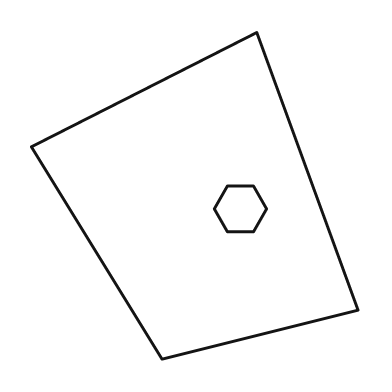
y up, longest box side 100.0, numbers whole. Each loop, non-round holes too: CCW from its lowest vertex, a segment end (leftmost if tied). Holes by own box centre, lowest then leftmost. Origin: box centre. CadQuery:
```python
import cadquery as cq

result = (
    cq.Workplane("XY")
    .moveTo(-10.0, -50.0)
    .lineTo(50.0, -35.0)
    .lineTo(19.0, 50.0)
    .lineTo(-50.0, 15.0)
    .close()
    .moveTo(10.0, -11.0)
    .lineTo(18.0, -11.0)
    .lineTo(22.0, -4.0)
    .lineTo(18.0, 3.0)
    .lineTo(10.0, 3.0)
    .lineTo(6.0, -4.0)
    .close()
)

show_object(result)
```